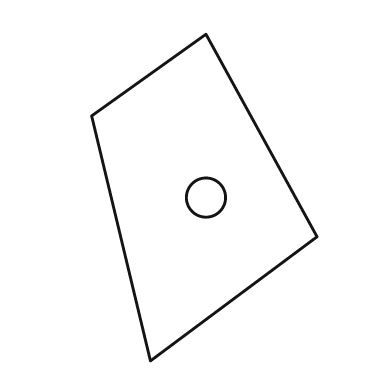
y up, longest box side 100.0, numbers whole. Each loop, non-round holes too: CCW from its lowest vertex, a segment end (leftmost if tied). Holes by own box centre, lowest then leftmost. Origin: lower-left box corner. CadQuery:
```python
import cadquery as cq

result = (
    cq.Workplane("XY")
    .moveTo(18.0, 0.0)
    .lineTo(69.0, 38.0)
    .lineTo(35.0, 100.0)
    .lineTo(0.0, 75.0)
    .close()
    .moveTo(35.0, 50.0)
    .circle(6.0)
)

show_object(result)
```